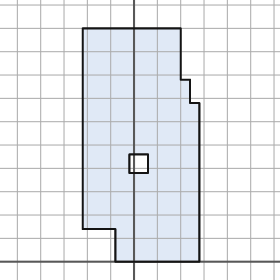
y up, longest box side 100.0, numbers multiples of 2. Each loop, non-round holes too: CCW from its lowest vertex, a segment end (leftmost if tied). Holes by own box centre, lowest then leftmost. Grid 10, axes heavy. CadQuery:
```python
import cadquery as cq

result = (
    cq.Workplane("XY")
    .moveTo(-8.0, 0.0)
    .lineTo(28.0, 0.0)
    .lineTo(28.0, 68.0)
    .lineTo(24.0, 68.0)
    .lineTo(24.0, 78.0)
    .lineTo(20.0, 78.0)
    .lineTo(20.0, 100.0)
    .lineTo(-22.0, 100.0)
    .lineTo(-22.0, 14.0)
    .lineTo(-8.0, 14.0)
    .close()
    .moveTo(-2.0, 38.0)
    .lineTo(6.0, 38.0)
    .lineTo(6.0, 46.0)
    .lineTo(-2.0, 46.0)
    .close()
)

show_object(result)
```